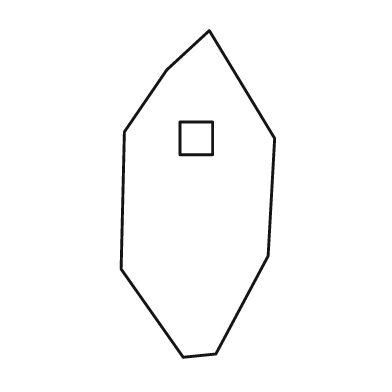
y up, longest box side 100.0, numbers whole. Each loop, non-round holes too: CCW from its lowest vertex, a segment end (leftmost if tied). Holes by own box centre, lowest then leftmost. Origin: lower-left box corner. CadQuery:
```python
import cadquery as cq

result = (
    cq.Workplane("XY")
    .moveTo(19.0, 0.0)
    .lineTo(29.0, 1.0)
    .lineTo(45.0, 31.0)
    .lineTo(47.0, 67.0)
    .lineTo(27.0, 100.0)
    .lineTo(14.0, 88.0)
    .lineTo(1.0, 69.0)
    .lineTo(0.0, 27.0)
    .close()
    .moveTo(18.0, 62.0)
    .lineTo(28.0, 62.0)
    .lineTo(28.0, 72.0)
    .lineTo(18.0, 72.0)
    .close()
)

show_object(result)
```